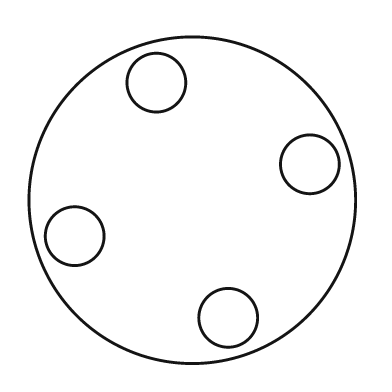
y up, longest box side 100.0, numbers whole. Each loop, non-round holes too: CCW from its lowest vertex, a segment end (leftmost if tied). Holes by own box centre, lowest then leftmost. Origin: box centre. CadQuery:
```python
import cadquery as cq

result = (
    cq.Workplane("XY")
    .moveTo(0.0, 0.0)
    .circle(50.0)
    .moveTo(11.0, -36.0)
    .circle(9.0)
    .moveTo(-36.0, -11.0)
    .circle(9.0)
    .moveTo(36.0, 11.0)
    .circle(9.0)
    .moveTo(-11.0, 36.0)
    .circle(9.0)
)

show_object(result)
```